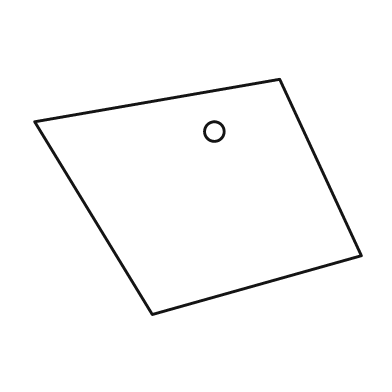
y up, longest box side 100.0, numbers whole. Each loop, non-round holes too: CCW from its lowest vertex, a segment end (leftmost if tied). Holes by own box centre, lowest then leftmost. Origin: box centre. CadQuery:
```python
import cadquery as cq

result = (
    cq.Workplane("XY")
    .moveTo(-14.0, -36.0)
    .lineTo(50.0, -18.0)
    .lineTo(25.0, 36.0)
    .lineTo(-50.0, 23.0)
    .close()
    .moveTo(5.0, 20.0)
    .circle(3.0)
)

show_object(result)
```